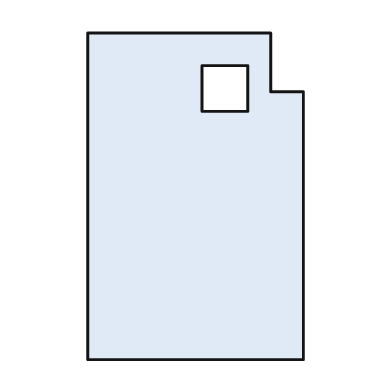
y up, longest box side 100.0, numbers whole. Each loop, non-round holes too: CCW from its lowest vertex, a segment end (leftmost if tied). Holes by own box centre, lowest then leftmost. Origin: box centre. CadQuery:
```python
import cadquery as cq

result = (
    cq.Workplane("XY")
    .moveTo(-33.0, -50.0)
    .lineTo(33.0, -50.0)
    .lineTo(33.0, 32.0)
    .lineTo(23.0, 32.0)
    .lineTo(23.0, 50.0)
    .lineTo(-33.0, 50.0)
    .close()
    .moveTo(2.0, 26.0)
    .lineTo(16.0, 26.0)
    .lineTo(16.0, 40.0)
    .lineTo(2.0, 40.0)
    .close()
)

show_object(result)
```